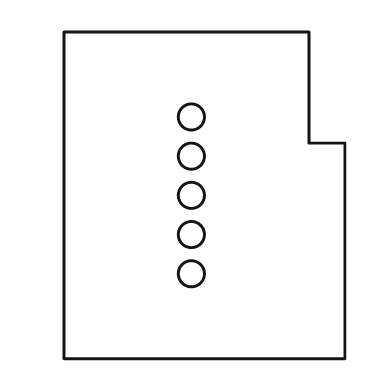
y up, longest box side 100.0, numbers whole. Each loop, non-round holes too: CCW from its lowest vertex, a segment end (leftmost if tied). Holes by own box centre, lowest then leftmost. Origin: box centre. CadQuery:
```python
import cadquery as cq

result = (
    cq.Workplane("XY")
    .moveTo(-43.0, -50.0)
    .lineTo(43.0, -50.0)
    .lineTo(43.0, 16.0)
    .lineTo(32.0, 16.0)
    .lineTo(32.0, 50.0)
    .lineTo(-43.0, 50.0)
    .close()
    .moveTo(-4.0, -24.0)
    .circle(4.0)
    .moveTo(-4.0, -12.0)
    .circle(4.0)
    .moveTo(-4.0, 0.0)
    .circle(4.0)
    .moveTo(-4.0, 12.0)
    .circle(4.0)
    .moveTo(-4.0, 24.0)
    .circle(4.0)
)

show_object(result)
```